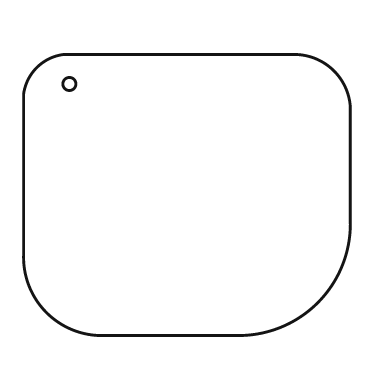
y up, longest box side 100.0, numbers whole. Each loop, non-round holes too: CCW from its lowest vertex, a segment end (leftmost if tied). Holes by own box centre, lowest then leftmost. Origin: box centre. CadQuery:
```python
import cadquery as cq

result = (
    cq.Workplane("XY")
    .moveTo(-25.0, -43.0)
    .lineTo(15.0, -43.0)
    .threePointArc((40.0, -33.0), (50.0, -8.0))
    .lineTo(50.0, 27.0)
    .threePointArc((45.0, 38.0), (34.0, 43.0))
    .lineTo(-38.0, 43.0)
    .threePointArc((-46.0, 39.0), (-50.0, 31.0))
    .lineTo(-50.0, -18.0)
    .threePointArc((-43.0, -36.0), (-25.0, -43.0))
    .close()
    .moveTo(-36.0, 34.0)
    .circle(2.0)
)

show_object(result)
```